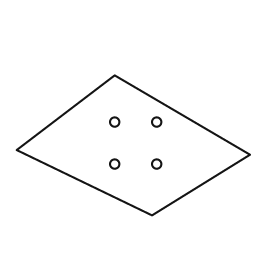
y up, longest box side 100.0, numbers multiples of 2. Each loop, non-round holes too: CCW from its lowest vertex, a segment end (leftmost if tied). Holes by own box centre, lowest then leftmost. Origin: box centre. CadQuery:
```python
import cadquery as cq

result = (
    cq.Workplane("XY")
    .moveTo(8.0, -30.0)
    .lineTo(50.0, -4.0)
    .lineTo(-8.0, 30.0)
    .lineTo(-50.0, -2.0)
    .close()
    .moveTo(-8.0, -8.0)
    .circle(2.0)
    .moveTo(10.0, -8.0)
    .circle(2.0)
    .moveTo(-8.0, 10.0)
    .circle(2.0)
    .moveTo(10.0, 10.0)
    .circle(2.0)
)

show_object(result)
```